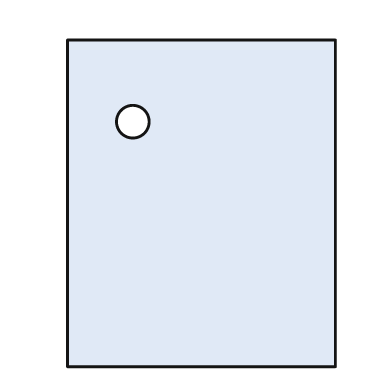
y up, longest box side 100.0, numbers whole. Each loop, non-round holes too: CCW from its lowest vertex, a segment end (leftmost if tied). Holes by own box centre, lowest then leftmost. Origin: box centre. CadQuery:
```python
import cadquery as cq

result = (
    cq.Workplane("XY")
    .moveTo(-41.0, -50.0)
    .lineTo(41.0, -50.0)
    .lineTo(41.0, 50.0)
    .lineTo(-41.0, 50.0)
    .close()
    .moveTo(-21.0, 25.0)
    .circle(5.0)
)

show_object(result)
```